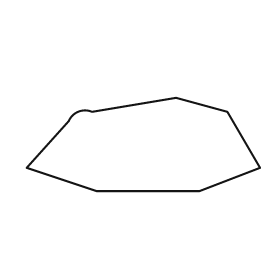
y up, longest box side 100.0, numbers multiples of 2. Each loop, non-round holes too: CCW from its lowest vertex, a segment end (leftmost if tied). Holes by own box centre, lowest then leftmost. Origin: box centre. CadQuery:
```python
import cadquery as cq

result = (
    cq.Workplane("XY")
    .moveTo(-20.0, -20.0)
    .lineTo(24.0, -20.0)
    .lineTo(50.0, -10.0)
    .lineTo(36.0, 14.0)
    .lineTo(14.0, 20.0)
    .lineTo(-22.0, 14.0)
    .threePointArc((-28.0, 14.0), (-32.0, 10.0))
    .lineTo(-50.0, -10.0)
    .close()
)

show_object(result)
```